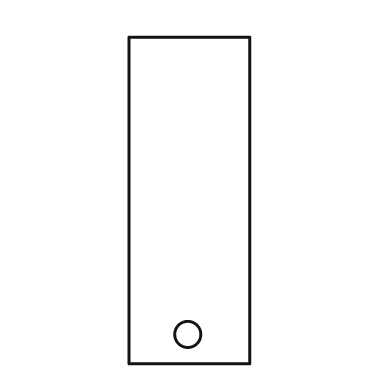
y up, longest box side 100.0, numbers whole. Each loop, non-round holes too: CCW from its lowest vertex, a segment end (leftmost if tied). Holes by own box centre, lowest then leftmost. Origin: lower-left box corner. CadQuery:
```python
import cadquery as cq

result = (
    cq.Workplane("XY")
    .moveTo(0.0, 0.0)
    .lineTo(37.0, 0.0)
    .lineTo(37.0, 100.0)
    .lineTo(0.0, 100.0)
    .close()
    .moveTo(18.0, 9.0)
    .circle(4.0)
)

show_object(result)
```